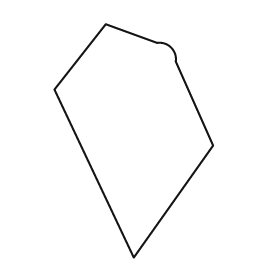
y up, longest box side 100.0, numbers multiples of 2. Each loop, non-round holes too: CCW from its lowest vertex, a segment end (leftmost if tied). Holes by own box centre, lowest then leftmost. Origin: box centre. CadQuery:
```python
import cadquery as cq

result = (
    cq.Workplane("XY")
    .moveTo(0.0, -50.0)
    .lineTo(34.0, -2.0)
    .lineTo(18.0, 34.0)
    .threePointArc((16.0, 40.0), (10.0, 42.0))
    .lineTo(-12.0, 50.0)
    .lineTo(-34.0, 22.0)
    .close()
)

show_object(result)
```